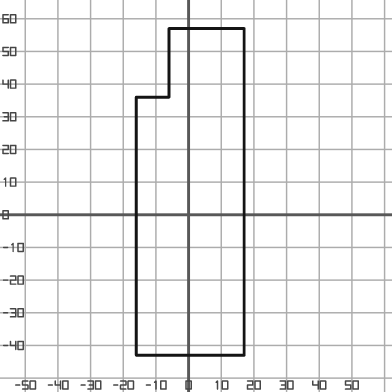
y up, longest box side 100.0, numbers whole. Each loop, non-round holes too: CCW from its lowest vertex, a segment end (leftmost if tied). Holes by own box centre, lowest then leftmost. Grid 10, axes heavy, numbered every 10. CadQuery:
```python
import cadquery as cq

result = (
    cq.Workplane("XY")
    .moveTo(-16.0, -43.0)
    .lineTo(17.0, -43.0)
    .lineTo(17.0, 57.0)
    .lineTo(-6.0, 57.0)
    .lineTo(-6.0, 36.0)
    .lineTo(-16.0, 36.0)
    .close()
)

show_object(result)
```